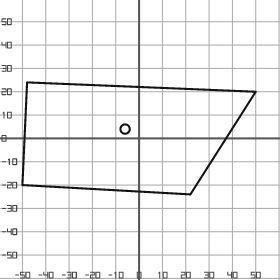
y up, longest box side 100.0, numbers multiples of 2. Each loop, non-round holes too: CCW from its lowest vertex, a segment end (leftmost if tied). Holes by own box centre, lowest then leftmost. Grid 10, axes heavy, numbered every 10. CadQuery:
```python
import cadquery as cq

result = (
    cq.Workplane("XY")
    .moveTo(22.0, -24.0)
    .lineTo(50.0, 20.0)
    .lineTo(-48.0, 24.0)
    .lineTo(-50.0, -20.0)
    .close()
    .moveTo(-6.0, 4.0)
    .circle(2.0)
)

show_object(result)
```